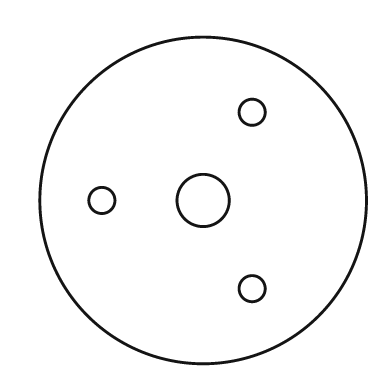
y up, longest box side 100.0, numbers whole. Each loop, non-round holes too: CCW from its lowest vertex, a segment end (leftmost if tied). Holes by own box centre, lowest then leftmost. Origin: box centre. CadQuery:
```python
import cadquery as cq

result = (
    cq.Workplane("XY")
    .moveTo(0.0, 0.0)
    .circle(50.0)
    .moveTo(15.0, -27.0)
    .circle(4.0)
    .moveTo(-31.0, 0.0)
    .circle(4.0)
    .moveTo(0.0, 0.0)
    .circle(8.0)
    .moveTo(15.0, 27.0)
    .circle(4.0)
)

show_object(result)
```